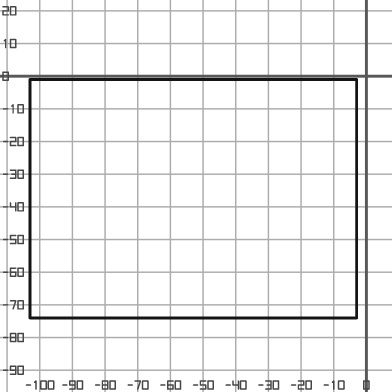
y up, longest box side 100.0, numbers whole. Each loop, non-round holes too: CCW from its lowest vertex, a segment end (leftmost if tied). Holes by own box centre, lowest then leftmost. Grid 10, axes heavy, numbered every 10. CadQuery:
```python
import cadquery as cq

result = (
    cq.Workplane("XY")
    .moveTo(-103.0, -74.0)
    .lineTo(-3.0, -74.0)
    .lineTo(-3.0, -1.0)
    .lineTo(-103.0, -1.0)
    .close()
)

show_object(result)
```